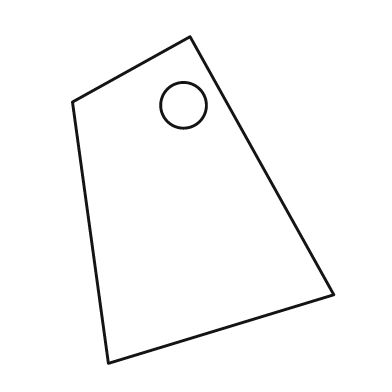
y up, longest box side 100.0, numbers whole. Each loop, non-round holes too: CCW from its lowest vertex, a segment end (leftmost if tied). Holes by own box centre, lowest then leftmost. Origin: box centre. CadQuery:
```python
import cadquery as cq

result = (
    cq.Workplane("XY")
    .moveTo(-29.0, -50.0)
    .lineTo(40.0, -29.0)
    .lineTo(-4.0, 50.0)
    .lineTo(-40.0, 30.0)
    .close()
    .moveTo(-6.0, 29.0)
    .circle(7.0)
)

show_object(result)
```